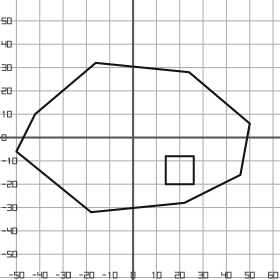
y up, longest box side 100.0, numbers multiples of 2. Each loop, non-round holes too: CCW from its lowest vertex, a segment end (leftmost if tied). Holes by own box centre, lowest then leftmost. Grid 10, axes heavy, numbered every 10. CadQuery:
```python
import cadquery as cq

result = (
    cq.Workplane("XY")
    .moveTo(-18.0, -32.0)
    .lineTo(22.0, -28.0)
    .lineTo(46.0, -16.0)
    .lineTo(50.0, 6.0)
    .lineTo(24.0, 28.0)
    .lineTo(-16.0, 32.0)
    .lineTo(-42.0, 10.0)
    .lineTo(-50.0, -6.0)
    .close()
    .moveTo(14.0, -20.0)
    .lineTo(26.0, -20.0)
    .lineTo(26.0, -8.0)
    .lineTo(14.0, -8.0)
    .close()
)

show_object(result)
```